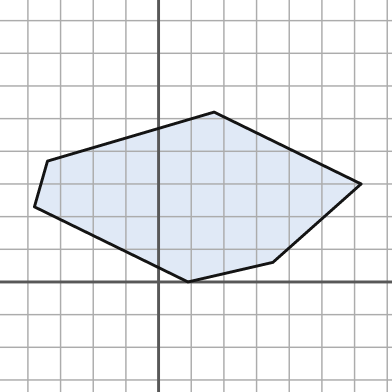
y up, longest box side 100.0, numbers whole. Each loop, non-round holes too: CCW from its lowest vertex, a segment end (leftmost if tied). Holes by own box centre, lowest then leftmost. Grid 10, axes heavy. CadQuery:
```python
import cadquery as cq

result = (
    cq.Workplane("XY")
    .moveTo(9.0, 0.0)
    .lineTo(35.0, 6.0)
    .lineTo(62.0, 30.0)
    .lineTo(17.0, 52.0)
    .lineTo(-34.0, 37.0)
    .lineTo(-38.0, 23.0)
    .close()
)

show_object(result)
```